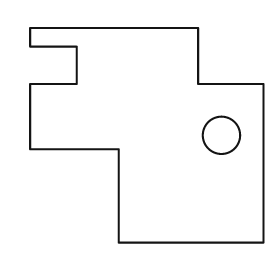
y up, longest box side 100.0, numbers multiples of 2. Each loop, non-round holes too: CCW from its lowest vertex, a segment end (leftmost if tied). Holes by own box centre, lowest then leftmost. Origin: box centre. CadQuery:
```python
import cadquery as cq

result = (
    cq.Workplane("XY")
    .moveTo(-12.0, -46.0)
    .lineTo(50.0, -46.0)
    .lineTo(50.0, 22.0)
    .lineTo(22.0, 22.0)
    .lineTo(22.0, 46.0)
    .lineTo(-50.0, 46.0)
    .lineTo(-50.0, 38.0)
    .lineTo(-30.0, 38.0)
    .lineTo(-30.0, 22.0)
    .lineTo(-50.0, 22.0)
    .lineTo(-50.0, -6.0)
    .lineTo(-12.0, -6.0)
    .close()
    .moveTo(32.0, 0.0)
    .circle(8.0)
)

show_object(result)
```